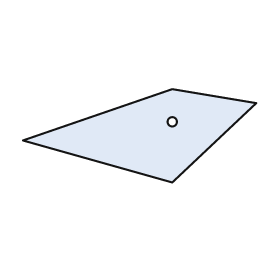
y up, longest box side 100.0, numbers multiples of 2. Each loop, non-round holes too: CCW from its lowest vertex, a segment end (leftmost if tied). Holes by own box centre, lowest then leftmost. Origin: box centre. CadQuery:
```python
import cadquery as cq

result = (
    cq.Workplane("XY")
    .moveTo(14.0, -20.0)
    .lineTo(50.0, 14.0)
    .lineTo(14.0, 20.0)
    .lineTo(-50.0, -2.0)
    .close()
    .moveTo(14.0, 6.0)
    .circle(2.0)
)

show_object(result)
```